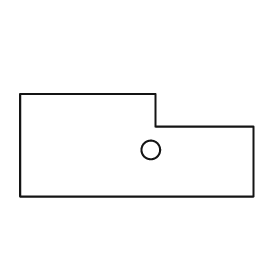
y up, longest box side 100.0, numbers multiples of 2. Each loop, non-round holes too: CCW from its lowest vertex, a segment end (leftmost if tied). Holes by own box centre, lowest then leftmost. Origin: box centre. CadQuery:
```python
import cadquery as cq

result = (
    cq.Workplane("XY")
    .moveTo(-50.0, -22.0)
    .lineTo(50.0, -22.0)
    .lineTo(50.0, 8.0)
    .lineTo(8.0, 8.0)
    .lineTo(8.0, 22.0)
    .lineTo(-50.0, 22.0)
    .close()
    .moveTo(6.0, -2.0)
    .circle(4.0)
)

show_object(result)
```